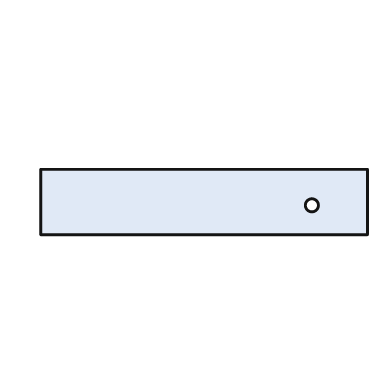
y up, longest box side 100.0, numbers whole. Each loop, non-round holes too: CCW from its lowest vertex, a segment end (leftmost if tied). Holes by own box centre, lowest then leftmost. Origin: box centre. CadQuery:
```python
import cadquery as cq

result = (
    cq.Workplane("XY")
    .moveTo(-50.0, -10.0)
    .lineTo(50.0, -10.0)
    .lineTo(50.0, 10.0)
    .lineTo(-50.0, 10.0)
    .close()
    .moveTo(33.0, -1.0)
    .circle(2.0)
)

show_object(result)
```